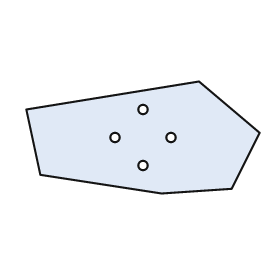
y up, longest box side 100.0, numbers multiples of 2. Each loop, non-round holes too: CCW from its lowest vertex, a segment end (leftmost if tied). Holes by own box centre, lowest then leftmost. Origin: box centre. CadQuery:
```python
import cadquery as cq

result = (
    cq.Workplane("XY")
    .moveTo(8.0, -24.0)
    .lineTo(38.0, -22.0)
    .lineTo(50.0, 2.0)
    .lineTo(24.0, 24.0)
    .lineTo(-50.0, 12.0)
    .lineTo(-44.0, -16.0)
    .close()
    .moveTo(0.0, -12.0)
    .circle(2.0)
    .moveTo(-12.0, 0.0)
    .circle(2.0)
    .moveTo(12.0, 0.0)
    .circle(2.0)
    .moveTo(0.0, 12.0)
    .circle(2.0)
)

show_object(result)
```